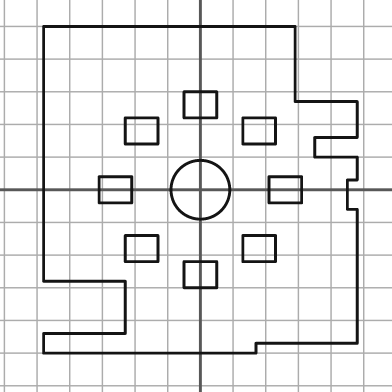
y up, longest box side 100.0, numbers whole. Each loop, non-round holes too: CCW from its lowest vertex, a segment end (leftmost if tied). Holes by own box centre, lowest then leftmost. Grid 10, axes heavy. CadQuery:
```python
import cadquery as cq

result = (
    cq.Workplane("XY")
    .moveTo(-48.0, -50.0)
    .lineTo(17.0, -50.0)
    .lineTo(17.0, -47.0)
    .lineTo(48.0, -47.0)
    .lineTo(48.0, -6.0)
    .lineTo(45.0, -6.0)
    .lineTo(45.0, 3.0)
    .lineTo(48.0, 3.0)
    .lineTo(48.0, 10.0)
    .lineTo(35.0, 10.0)
    .lineTo(35.0, 16.0)
    .lineTo(48.0, 16.0)
    .lineTo(48.0, 27.0)
    .lineTo(29.0, 27.0)
    .lineTo(29.0, 50.0)
    .lineTo(-48.0, 50.0)
    .lineTo(-48.0, -28.0)
    .lineTo(-23.0, -28.0)
    .lineTo(-23.0, -44.0)
    .lineTo(-48.0, -44.0)
    .close()
    .moveTo(-5.0, -30.0)
    .lineTo(5.0, -30.0)
    .lineTo(5.0, -22.0)
    .lineTo(-5.0, -22.0)
    .close()
    .moveTo(-23.0, -22.0)
    .lineTo(-13.0, -22.0)
    .lineTo(-13.0, -14.0)
    .lineTo(-23.0, -14.0)
    .close()
    .moveTo(13.0, -22.0)
    .lineTo(23.0, -22.0)
    .lineTo(23.0, -14.0)
    .lineTo(13.0, -14.0)
    .close()
    .moveTo(-31.0, -4.0)
    .lineTo(-21.0, -4.0)
    .lineTo(-21.0, 4.0)
    .lineTo(-31.0, 4.0)
    .close()
    .moveTo(0.0, 0.0)
    .circle(9.0)
    .moveTo(21.0, -4.0)
    .lineTo(31.0, -4.0)
    .lineTo(31.0, 4.0)
    .lineTo(21.0, 4.0)
    .close()
    .moveTo(-23.0, 14.0)
    .lineTo(-13.0, 14.0)
    .lineTo(-13.0, 22.0)
    .lineTo(-23.0, 22.0)
    .close()
    .moveTo(13.0, 14.0)
    .lineTo(23.0, 14.0)
    .lineTo(23.0, 22.0)
    .lineTo(13.0, 22.0)
    .close()
    .moveTo(-5.0, 22.0)
    .lineTo(5.0, 22.0)
    .lineTo(5.0, 30.0)
    .lineTo(-5.0, 30.0)
    .close()
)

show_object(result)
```